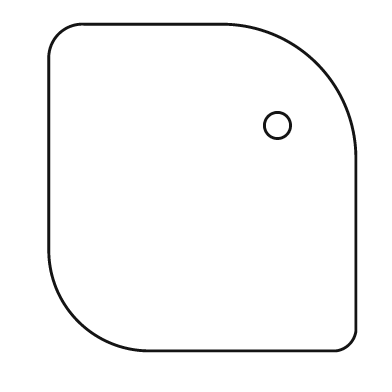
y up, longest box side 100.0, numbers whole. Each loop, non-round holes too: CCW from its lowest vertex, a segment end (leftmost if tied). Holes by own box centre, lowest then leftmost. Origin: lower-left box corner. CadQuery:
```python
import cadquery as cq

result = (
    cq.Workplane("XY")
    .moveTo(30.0, 0.0)
    .lineTo(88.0, 0.0)
    .threePointArc((92.0, 2.0), (94.0, 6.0))
    .lineTo(94.0, 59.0)
    .threePointArc((82.0, 88.0), (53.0, 100.0))
    .lineTo(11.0, 100.0)
    .threePointArc((3.0, 97.0), (0.0, 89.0))
    .lineTo(0.0, 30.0)
    .threePointArc((9.0, 9.0), (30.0, 0.0))
    .close()
    .moveTo(70.0, 69.0)
    .circle(4.0)
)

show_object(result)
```